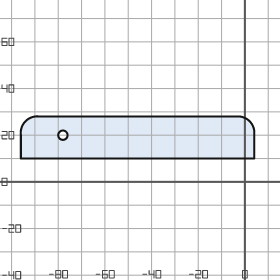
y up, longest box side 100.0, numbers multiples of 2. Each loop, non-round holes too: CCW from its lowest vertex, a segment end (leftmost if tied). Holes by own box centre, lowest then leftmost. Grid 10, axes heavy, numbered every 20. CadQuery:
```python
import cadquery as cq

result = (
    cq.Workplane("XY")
    .moveTo(-96.0, 10.0)
    .lineTo(4.0, 10.0)
    .lineTo(4.0, 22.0)
    .threePointArc((2.0, 26.0), (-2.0, 28.0))
    .lineTo(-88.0, 28.0)
    .threePointArc((-94.0, 26.0), (-96.0, 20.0))
    .close()
    .moveTo(-78.0, 20.0)
    .circle(2.0)
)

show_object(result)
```